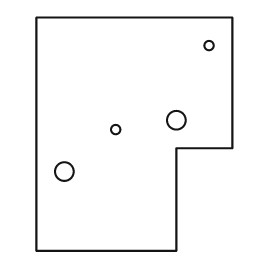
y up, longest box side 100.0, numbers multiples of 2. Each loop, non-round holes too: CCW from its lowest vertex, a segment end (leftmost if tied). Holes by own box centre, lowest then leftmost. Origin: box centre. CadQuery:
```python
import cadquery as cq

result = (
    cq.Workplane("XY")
    .moveTo(-42.0, -50.0)
    .lineTo(18.0, -50.0)
    .lineTo(18.0, -6.0)
    .lineTo(42.0, -6.0)
    .lineTo(42.0, 50.0)
    .lineTo(-42.0, 50.0)
    .close()
    .moveTo(-30.0, -16.0)
    .circle(4.0)
    .moveTo(-8.0, 2.0)
    .circle(2.0)
    .moveTo(18.0, 6.0)
    .circle(4.0)
    .moveTo(32.0, 38.0)
    .circle(2.0)
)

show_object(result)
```